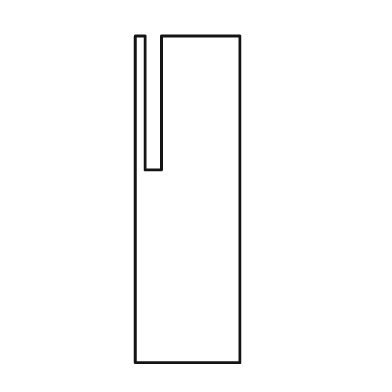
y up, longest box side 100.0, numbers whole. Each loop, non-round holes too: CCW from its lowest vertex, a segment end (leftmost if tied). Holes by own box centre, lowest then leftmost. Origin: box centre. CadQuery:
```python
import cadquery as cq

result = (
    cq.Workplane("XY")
    .moveTo(-16.0, -50.0)
    .lineTo(16.0, -50.0)
    .lineTo(16.0, 50.0)
    .lineTo(-8.0, 50.0)
    .lineTo(-8.0, 9.0)
    .lineTo(-13.0, 9.0)
    .lineTo(-13.0, 50.0)
    .lineTo(-16.0, 50.0)
    .close()
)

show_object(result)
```